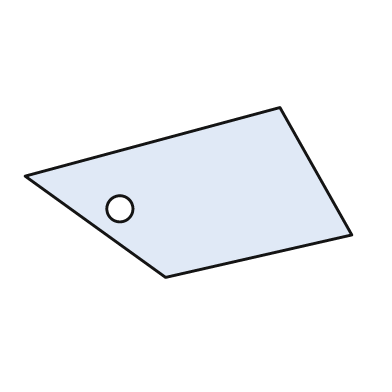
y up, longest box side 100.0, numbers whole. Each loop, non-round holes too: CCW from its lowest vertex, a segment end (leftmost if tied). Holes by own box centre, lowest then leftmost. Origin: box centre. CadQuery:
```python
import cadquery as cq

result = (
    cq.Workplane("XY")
    .moveTo(-7.0, -26.0)
    .lineTo(50.0, -13.0)
    .lineTo(28.0, 26.0)
    .lineTo(-50.0, 5.0)
    .close()
    .moveTo(-21.0, -5.0)
    .circle(4.0)
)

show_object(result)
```